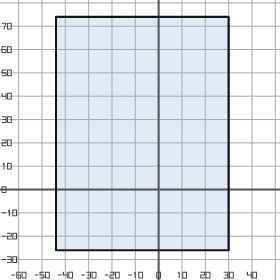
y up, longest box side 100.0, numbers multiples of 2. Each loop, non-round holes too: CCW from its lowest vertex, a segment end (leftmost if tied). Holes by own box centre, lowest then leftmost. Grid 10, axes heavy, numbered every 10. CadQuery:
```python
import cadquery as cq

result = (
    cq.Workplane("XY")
    .moveTo(-44.0, -26.0)
    .lineTo(30.0, -26.0)
    .lineTo(30.0, 74.0)
    .lineTo(-44.0, 74.0)
    .close()
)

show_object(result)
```